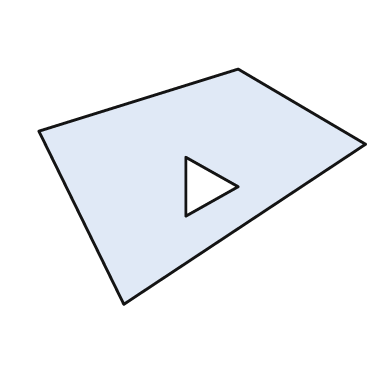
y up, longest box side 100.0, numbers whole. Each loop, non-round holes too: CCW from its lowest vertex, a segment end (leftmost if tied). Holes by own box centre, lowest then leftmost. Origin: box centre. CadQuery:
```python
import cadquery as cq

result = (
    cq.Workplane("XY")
    .moveTo(-24.0, -36.0)
    .lineTo(50.0, 13.0)
    .lineTo(11.0, 36.0)
    .lineTo(-50.0, 17.0)
    .close()
    .moveTo(-5.0, -9.0)
    .lineTo(11.0, 0.0)
    .lineTo(-5.0, 9.0)
    .close()
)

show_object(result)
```